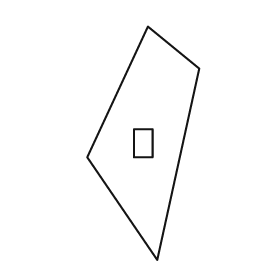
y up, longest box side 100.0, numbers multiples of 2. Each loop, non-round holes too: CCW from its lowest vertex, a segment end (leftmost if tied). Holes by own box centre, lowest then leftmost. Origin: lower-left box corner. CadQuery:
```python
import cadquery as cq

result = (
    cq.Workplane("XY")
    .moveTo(30.0, 0.0)
    .lineTo(48.0, 82.0)
    .lineTo(26.0, 100.0)
    .lineTo(0.0, 44.0)
    .close()
    .moveTo(20.0, 44.0)
    .lineTo(28.0, 44.0)
    .lineTo(28.0, 56.0)
    .lineTo(20.0, 56.0)
    .close()
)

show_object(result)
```